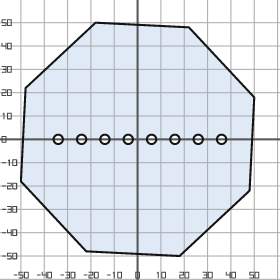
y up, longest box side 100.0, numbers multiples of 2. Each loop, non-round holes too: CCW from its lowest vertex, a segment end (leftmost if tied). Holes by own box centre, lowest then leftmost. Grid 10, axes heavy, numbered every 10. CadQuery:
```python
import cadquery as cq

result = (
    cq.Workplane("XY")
    .moveTo(18.0, -50.0)
    .lineTo(48.0, -22.0)
    .lineTo(50.0, 18.0)
    .lineTo(22.0, 48.0)
    .lineTo(-18.0, 50.0)
    .lineTo(-48.0, 22.0)
    .lineTo(-50.0, -18.0)
    .lineTo(-22.0, -48.0)
    .close()
    .moveTo(-34.0, 0.0)
    .circle(2.0)
    .moveTo(-24.0, 0.0)
    .circle(2.0)
    .moveTo(-14.0, 0.0)
    .circle(2.0)
    .moveTo(-4.0, 0.0)
    .circle(2.0)
    .moveTo(6.0, 0.0)
    .circle(2.0)
    .moveTo(16.0, 0.0)
    .circle(2.0)
    .moveTo(26.0, 0.0)
    .circle(2.0)
    .moveTo(36.0, 0.0)
    .circle(2.0)
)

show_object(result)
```